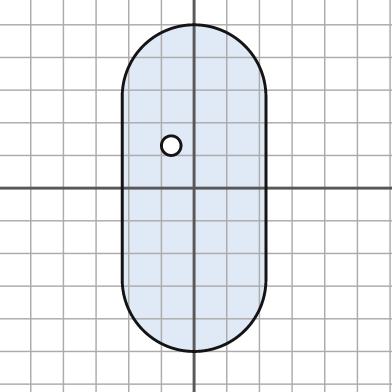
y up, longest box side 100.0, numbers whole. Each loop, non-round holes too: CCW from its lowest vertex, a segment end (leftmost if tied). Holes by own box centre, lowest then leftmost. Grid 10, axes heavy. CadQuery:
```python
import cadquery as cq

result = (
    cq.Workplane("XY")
    .moveTo(-22.0, -28.0)
    .threePointArc((0.0, -50.0), (22.0, -28.0))
    .lineTo(22.0, 28.0)
    .threePointArc((0.0, 50.0), (-22.0, 28.0))
    .close()
    .moveTo(-7.0, 13.0)
    .circle(3.0)
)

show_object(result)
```